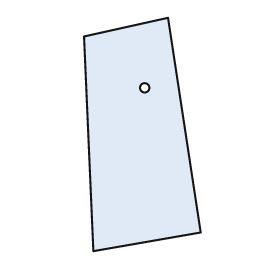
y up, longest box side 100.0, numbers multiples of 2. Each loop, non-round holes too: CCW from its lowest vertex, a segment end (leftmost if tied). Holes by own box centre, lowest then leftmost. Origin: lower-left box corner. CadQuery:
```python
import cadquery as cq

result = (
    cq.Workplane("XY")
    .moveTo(4.0, 0.0)
    .lineTo(50.0, 8.0)
    .lineTo(36.0, 100.0)
    .lineTo(0.0, 92.0)
    .close()
    .moveTo(26.0, 70.0)
    .circle(2.0)
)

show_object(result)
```